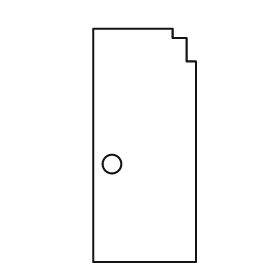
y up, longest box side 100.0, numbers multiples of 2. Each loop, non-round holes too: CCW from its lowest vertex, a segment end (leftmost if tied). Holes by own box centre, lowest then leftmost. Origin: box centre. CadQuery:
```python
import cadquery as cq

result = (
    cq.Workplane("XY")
    .moveTo(-22.0, -50.0)
    .lineTo(22.0, -50.0)
    .lineTo(22.0, 36.0)
    .lineTo(18.0, 36.0)
    .lineTo(18.0, 46.0)
    .lineTo(12.0, 46.0)
    .lineTo(12.0, 50.0)
    .lineTo(-22.0, 50.0)
    .close()
    .moveTo(-14.0, -8.0)
    .circle(4.0)
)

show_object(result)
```